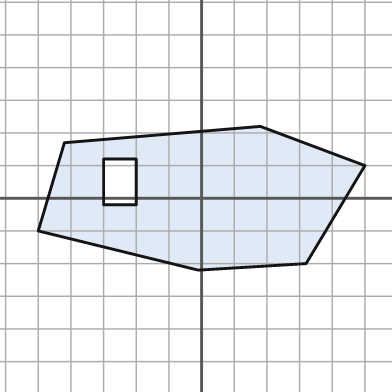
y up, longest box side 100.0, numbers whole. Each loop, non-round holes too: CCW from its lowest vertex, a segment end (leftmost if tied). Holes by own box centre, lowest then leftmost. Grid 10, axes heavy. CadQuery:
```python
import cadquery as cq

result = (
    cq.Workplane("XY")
    .moveTo(-1.0, -22.0)
    .lineTo(32.0, -20.0)
    .lineTo(50.0, 10.0)
    .lineTo(18.0, 22.0)
    .lineTo(-42.0, 17.0)
    .lineTo(-50.0, -10.0)
    .close()
    .moveTo(-30.0, -2.0)
    .lineTo(-20.0, -2.0)
    .lineTo(-20.0, 12.0)
    .lineTo(-30.0, 12.0)
    .close()
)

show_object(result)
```